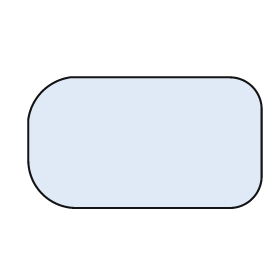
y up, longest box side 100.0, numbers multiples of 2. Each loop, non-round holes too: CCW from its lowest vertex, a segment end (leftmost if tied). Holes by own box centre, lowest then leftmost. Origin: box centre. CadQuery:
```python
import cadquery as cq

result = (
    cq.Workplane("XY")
    .moveTo(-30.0, -28.0)
    .lineTo(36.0, -28.0)
    .threePointArc((46.0, -24.0), (50.0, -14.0))
    .lineTo(50.0, 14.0)
    .threePointArc((46.0, 24.0), (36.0, 28.0))
    .lineTo(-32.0, 28.0)
    .threePointArc((-44.0, 22.0), (-50.0, 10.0))
    .lineTo(-50.0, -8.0)
    .threePointArc((-44.0, -22.0), (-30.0, -28.0))
    .close()
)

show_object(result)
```